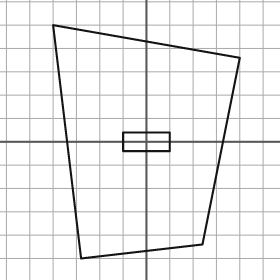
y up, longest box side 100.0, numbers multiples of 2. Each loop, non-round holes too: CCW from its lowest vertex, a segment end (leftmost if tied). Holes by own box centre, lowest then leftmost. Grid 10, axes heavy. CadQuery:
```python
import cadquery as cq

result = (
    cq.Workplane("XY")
    .moveTo(-28.0, -50.0)
    .lineTo(24.0, -44.0)
    .lineTo(40.0, 36.0)
    .lineTo(-40.0, 50.0)
    .close()
    .moveTo(-10.0, -4.0)
    .lineTo(10.0, -4.0)
    .lineTo(10.0, 4.0)
    .lineTo(-10.0, 4.0)
    .close()
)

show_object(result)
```